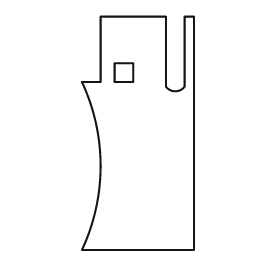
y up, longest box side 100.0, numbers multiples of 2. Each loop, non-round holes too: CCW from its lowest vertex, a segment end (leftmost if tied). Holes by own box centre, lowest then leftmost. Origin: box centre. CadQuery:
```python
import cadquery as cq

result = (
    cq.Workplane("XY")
    .moveTo(-24.0, -50.0)
    .lineTo(24.0, -50.0)
    .lineTo(24.0, 50.0)
    .lineTo(20.0, 50.0)
    .lineTo(20.0, 20.0)
    .threePointArc((16.0, 18.0), (12.0, 20.0))
    .lineTo(12.0, 50.0)
    .lineTo(-16.0, 50.0)
    .lineTo(-16.0, 22.0)
    .lineTo(-24.0, 22.0)
    .threePointArc((-16.0, -14.0), (-24.0, -50.0))
    .close()
    .moveTo(-10.0, 22.0)
    .lineTo(-2.0, 22.0)
    .lineTo(-2.0, 30.0)
    .lineTo(-10.0, 30.0)
    .close()
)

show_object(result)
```